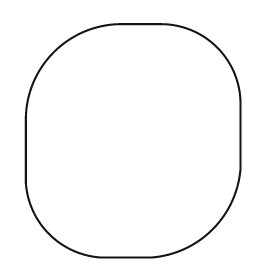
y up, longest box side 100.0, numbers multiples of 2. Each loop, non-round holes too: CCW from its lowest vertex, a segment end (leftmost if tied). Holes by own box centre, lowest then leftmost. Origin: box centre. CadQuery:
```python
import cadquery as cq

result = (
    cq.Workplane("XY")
    .moveTo(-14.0, -50.0)
    .lineTo(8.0, -50.0)
    .threePointArc((34.0, -38.0), (46.0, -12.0))
    .lineTo(46.0, 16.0)
    .threePointArc((36.0, 40.0), (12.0, 50.0))
    .lineTo(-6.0, 50.0)
    .threePointArc((-34.0, 38.0), (-46.0, 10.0))
    .lineTo(-46.0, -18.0)
    .threePointArc((-36.0, -40.0), (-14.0, -50.0))
    .close()
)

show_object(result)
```